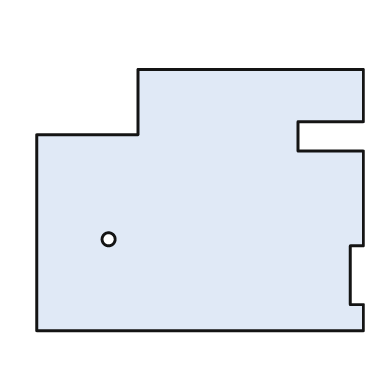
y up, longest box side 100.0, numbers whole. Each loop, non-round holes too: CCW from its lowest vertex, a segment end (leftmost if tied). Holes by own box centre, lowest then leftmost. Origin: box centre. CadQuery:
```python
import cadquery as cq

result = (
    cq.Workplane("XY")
    .moveTo(-50.0, -40.0)
    .lineTo(50.0, -40.0)
    .lineTo(50.0, -32.0)
    .lineTo(46.0, -32.0)
    .lineTo(46.0, -14.0)
    .lineTo(50.0, -14.0)
    .lineTo(50.0, 15.0)
    .lineTo(30.0, 15.0)
    .lineTo(30.0, 24.0)
    .lineTo(50.0, 24.0)
    .lineTo(50.0, 40.0)
    .lineTo(-19.0, 40.0)
    .lineTo(-19.0, 20.0)
    .lineTo(-50.0, 20.0)
    .close()
    .moveTo(-28.0, -12.0)
    .circle(2.0)
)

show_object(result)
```